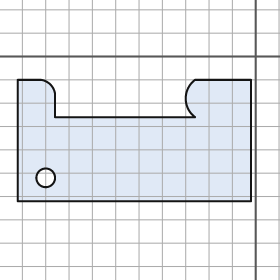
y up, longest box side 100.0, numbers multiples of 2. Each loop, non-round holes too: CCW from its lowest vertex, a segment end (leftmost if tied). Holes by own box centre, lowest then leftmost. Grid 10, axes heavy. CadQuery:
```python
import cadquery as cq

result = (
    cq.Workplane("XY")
    .moveTo(-102.0, -62.0)
    .lineTo(-2.0, -62.0)
    .lineTo(-2.0, -10.0)
    .lineTo(-26.0, -10.0)
    .threePointArc((-30.0, -18.0), (-26.0, -26.0))
    .lineTo(-86.0, -26.0)
    .lineTo(-86.0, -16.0)
    .threePointArc((-88.0, -12.0), (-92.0, -10.0))
    .lineTo(-102.0, -10.0)
    .close()
    .moveTo(-90.0, -52.0)
    .circle(4.0)
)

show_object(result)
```